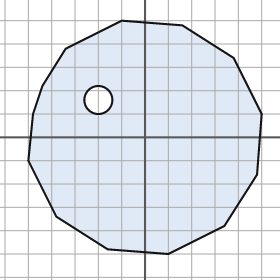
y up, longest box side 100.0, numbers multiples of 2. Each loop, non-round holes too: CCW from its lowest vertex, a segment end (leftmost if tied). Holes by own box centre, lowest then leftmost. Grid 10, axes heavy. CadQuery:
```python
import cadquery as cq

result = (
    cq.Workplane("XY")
    .moveTo(10.0, -50.0)
    .lineTo(34.0, -38.0)
    .lineTo(48.0, -16.0)
    .lineTo(50.0, 10.0)
    .lineTo(38.0, 34.0)
    .lineTo(16.0, 48.0)
    .lineTo(-10.0, 50.0)
    .lineTo(-34.0, 38.0)
    .lineTo(-44.0, 22.0)
    .lineTo(-48.0, 10.0)
    .lineTo(-50.0, -10.0)
    .lineTo(-38.0, -34.0)
    .lineTo(-16.0, -48.0)
    .close()
    .moveTo(-20.0, 16.0)
    .circle(6.0)
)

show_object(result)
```